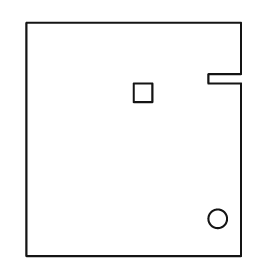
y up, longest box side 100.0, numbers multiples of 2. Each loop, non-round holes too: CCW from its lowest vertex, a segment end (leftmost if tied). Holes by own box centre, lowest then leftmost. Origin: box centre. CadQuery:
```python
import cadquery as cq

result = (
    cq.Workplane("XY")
    .moveTo(-46.0, -50.0)
    .lineTo(46.0, -50.0)
    .lineTo(46.0, 24.0)
    .lineTo(32.0, 24.0)
    .lineTo(32.0, 28.0)
    .lineTo(46.0, 28.0)
    .lineTo(46.0, 50.0)
    .lineTo(-46.0, 50.0)
    .close()
    .moveTo(36.0, -34.0)
    .circle(4.0)
    .moveTo(0.0, 16.0)
    .lineTo(8.0, 16.0)
    .lineTo(8.0, 24.0)
    .lineTo(0.0, 24.0)
    .close()
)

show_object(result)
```